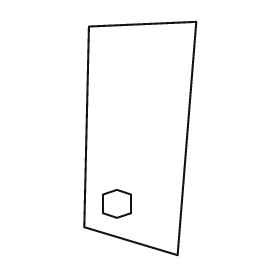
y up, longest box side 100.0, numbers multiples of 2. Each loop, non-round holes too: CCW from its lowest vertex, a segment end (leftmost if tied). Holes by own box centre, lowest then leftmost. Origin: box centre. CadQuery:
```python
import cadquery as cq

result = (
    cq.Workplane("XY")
    .moveTo(16.0, -50.0)
    .lineTo(24.0, 50.0)
    .lineTo(-22.0, 48.0)
    .lineTo(-24.0, -38.0)
    .close()
    .moveTo(-10.0, -34.0)
    .lineTo(-4.0, -32.0)
    .lineTo(-4.0, -24.0)
    .lineTo(-10.0, -22.0)
    .lineTo(-16.0, -24.0)
    .lineTo(-16.0, -32.0)
    .close()
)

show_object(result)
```